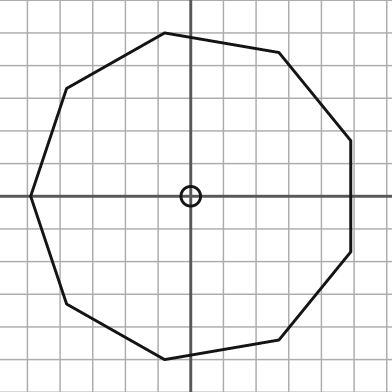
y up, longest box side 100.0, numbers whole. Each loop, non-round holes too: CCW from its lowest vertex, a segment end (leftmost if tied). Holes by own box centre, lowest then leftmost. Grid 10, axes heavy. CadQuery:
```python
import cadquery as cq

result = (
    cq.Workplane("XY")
    .moveTo(-8.0, -50.0)
    .lineTo(27.0, -44.0)
    .lineTo(49.0, -17.0)
    .lineTo(49.0, 17.0)
    .lineTo(27.0, 44.0)
    .lineTo(-8.0, 50.0)
    .lineTo(-38.0, 33.0)
    .lineTo(-49.0, 0.0)
    .lineTo(-38.0, -33.0)
    .close()
    .moveTo(0.0, 0.0)
    .circle(3.0)
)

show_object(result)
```